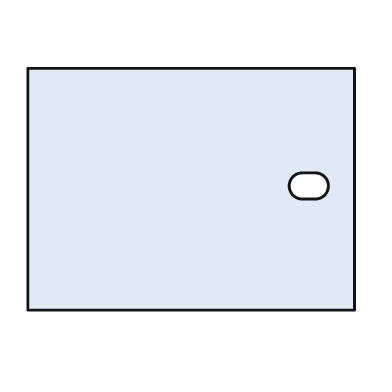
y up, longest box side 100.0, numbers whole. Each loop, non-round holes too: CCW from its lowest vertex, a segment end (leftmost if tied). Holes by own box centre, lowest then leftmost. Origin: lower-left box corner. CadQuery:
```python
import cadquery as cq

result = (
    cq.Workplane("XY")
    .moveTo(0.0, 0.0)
    .lineTo(100.0, 0.0)
    .lineTo(100.0, 74.0)
    .lineTo(0.0, 74.0)
    .close()
    .moveTo(84.0, 34.0)
    .lineTo(88.0, 34.0)
    .threePointArc((92.0, 38.0), (88.0, 42.0))
    .lineTo(84.0, 42.0)
    .threePointArc((80.0, 38.0), (84.0, 34.0))
    .close()
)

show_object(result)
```